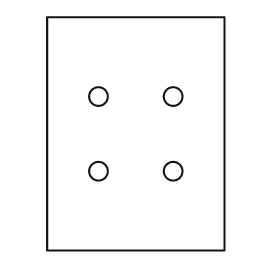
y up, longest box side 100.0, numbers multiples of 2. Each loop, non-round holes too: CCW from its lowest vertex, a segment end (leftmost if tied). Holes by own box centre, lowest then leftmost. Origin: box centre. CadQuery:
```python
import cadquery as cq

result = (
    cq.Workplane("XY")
    .moveTo(-38.0, -50.0)
    .lineTo(38.0, -50.0)
    .lineTo(38.0, 50.0)
    .lineTo(-38.0, 50.0)
    .close()
    .moveTo(-16.0, -16.0)
    .circle(4.0)
    .moveTo(16.0, -16.0)
    .circle(4.0)
    .moveTo(-16.0, 16.0)
    .circle(4.0)
    .moveTo(16.0, 16.0)
    .circle(4.0)
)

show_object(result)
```